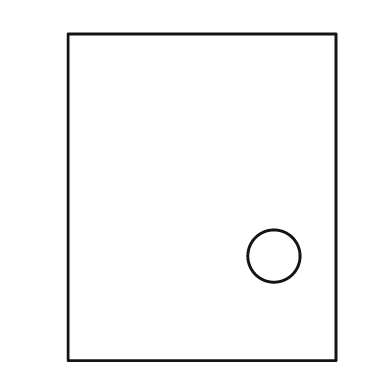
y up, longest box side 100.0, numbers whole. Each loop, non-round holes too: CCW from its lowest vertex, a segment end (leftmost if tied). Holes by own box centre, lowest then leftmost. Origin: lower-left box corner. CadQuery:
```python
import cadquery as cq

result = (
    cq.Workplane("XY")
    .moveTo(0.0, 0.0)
    .lineTo(82.0, 0.0)
    .lineTo(82.0, 100.0)
    .lineTo(0.0, 100.0)
    .close()
    .moveTo(63.0, 32.0)
    .circle(8.0)
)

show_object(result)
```